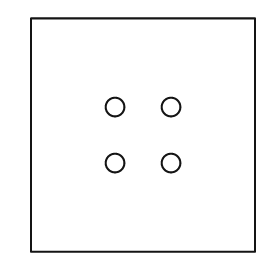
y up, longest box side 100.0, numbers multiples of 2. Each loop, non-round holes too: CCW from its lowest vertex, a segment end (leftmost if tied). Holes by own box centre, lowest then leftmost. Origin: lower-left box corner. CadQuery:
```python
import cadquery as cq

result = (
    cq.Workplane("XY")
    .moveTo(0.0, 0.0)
    .lineTo(96.0, 0.0)
    .lineTo(96.0, 100.0)
    .lineTo(0.0, 100.0)
    .close()
    .moveTo(36.0, 38.0)
    .circle(4.0)
    .moveTo(60.0, 38.0)
    .circle(4.0)
    .moveTo(36.0, 62.0)
    .circle(4.0)
    .moveTo(60.0, 62.0)
    .circle(4.0)
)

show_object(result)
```